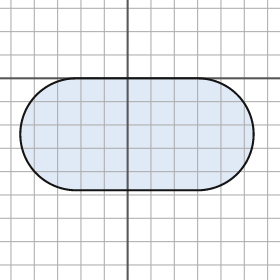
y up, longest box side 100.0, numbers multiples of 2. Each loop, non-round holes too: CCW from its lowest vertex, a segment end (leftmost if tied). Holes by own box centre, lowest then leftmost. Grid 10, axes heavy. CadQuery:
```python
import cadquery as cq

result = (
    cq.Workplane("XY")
    .moveTo(-22.0, -48.0)
    .lineTo(30.0, -48.0)
    .threePointArc((54.0, -24.0), (30.0, 0.0))
    .lineTo(-22.0, 0.0)
    .threePointArc((-46.0, -24.0), (-22.0, -48.0))
    .close()
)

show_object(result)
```